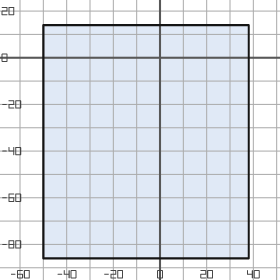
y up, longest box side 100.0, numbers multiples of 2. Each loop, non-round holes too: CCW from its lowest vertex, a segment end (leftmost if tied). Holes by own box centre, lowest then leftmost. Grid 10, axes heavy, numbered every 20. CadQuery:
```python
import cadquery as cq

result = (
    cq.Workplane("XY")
    .moveTo(-50.0, -86.0)
    .lineTo(38.0, -86.0)
    .lineTo(38.0, 14.0)
    .lineTo(-50.0, 14.0)
    .close()
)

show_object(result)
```